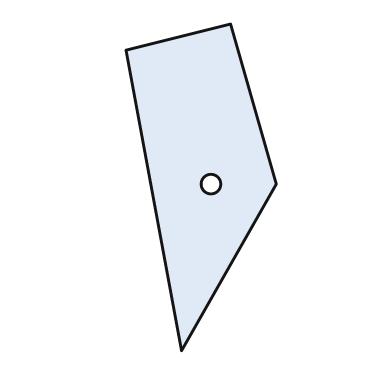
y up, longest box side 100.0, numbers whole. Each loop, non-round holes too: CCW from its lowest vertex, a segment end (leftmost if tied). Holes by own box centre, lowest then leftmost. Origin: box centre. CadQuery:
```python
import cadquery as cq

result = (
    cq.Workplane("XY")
    .moveTo(-6.0, -50.0)
    .lineTo(23.0, 1.0)
    .lineTo(9.0, 50.0)
    .lineTo(-23.0, 42.0)
    .close()
    .moveTo(3.0, 1.0)
    .circle(3.0)
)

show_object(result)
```